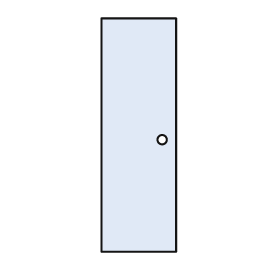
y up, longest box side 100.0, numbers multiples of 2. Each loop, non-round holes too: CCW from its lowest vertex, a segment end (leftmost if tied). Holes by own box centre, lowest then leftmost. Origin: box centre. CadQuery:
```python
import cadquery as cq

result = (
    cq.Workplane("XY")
    .moveTo(-16.0, -50.0)
    .lineTo(16.0, -50.0)
    .lineTo(16.0, 50.0)
    .lineTo(-16.0, 50.0)
    .close()
    .moveTo(10.0, -2.0)
    .circle(2.0)
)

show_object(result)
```